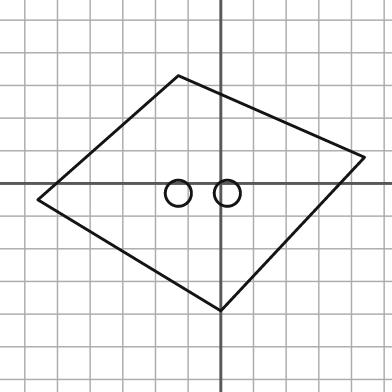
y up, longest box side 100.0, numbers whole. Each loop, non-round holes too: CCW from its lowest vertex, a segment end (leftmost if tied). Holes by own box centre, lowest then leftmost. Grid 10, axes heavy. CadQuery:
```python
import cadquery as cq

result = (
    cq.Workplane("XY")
    .moveTo(0.0, -39.0)
    .lineTo(44.0, 8.0)
    .lineTo(-13.0, 33.0)
    .lineTo(-56.0, -5.0)
    .close()
    .moveTo(-13.0, -3.0)
    .circle(4.0)
    .moveTo(2.0, -3.0)
    .circle(4.0)
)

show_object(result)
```